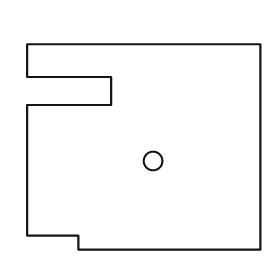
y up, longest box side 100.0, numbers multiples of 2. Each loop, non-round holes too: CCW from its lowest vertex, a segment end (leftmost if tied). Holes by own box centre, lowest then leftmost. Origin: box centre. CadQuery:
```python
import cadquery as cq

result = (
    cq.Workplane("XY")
    .moveTo(-28.0, -44.0)
    .lineTo(50.0, -44.0)
    .lineTo(50.0, 44.0)
    .lineTo(-50.0, 44.0)
    .lineTo(-50.0, 30.0)
    .lineTo(-14.0, 30.0)
    .lineTo(-14.0, 18.0)
    .lineTo(-50.0, 18.0)
    .lineTo(-50.0, -38.0)
    .lineTo(-28.0, -38.0)
    .close()
    .moveTo(4.0, -6.0)
    .circle(4.0)
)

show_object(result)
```